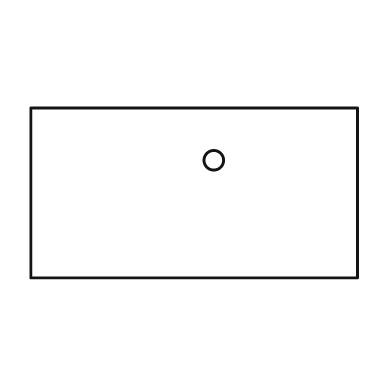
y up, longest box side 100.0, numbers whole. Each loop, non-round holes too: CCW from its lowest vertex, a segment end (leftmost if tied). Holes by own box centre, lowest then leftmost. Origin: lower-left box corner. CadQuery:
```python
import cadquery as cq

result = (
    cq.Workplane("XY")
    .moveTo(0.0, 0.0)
    .lineTo(100.0, 0.0)
    .lineTo(100.0, 52.0)
    .lineTo(0.0, 52.0)
    .close()
    .moveTo(56.0, 36.0)
    .circle(3.0)
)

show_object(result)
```